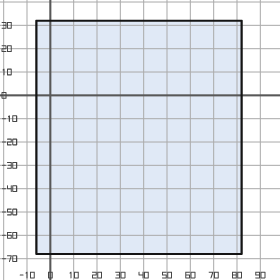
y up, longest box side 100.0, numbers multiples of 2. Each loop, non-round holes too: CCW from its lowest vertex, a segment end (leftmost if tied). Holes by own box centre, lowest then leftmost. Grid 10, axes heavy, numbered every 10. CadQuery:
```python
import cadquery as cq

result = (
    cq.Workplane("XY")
    .moveTo(-6.0, -68.0)
    .lineTo(82.0, -68.0)
    .lineTo(82.0, 32.0)
    .lineTo(-6.0, 32.0)
    .close()
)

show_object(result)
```